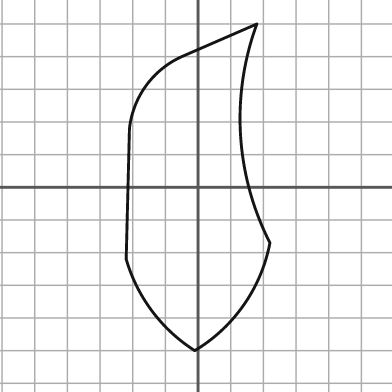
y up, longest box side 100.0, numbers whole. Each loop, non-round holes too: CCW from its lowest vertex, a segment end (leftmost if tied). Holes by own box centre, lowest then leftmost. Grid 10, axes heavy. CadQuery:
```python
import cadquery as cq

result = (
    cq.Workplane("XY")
    .moveTo(-1.0, -50.0)
    .threePointArc((14.0, -36.0), (22.0, -17.0))
    .threePointArc((13.0, 16.0), (18.0, 50.0))
    .lineTo(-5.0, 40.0)
    .threePointArc((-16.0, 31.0), (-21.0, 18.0))
    .lineTo(-22.0, -22.0)
    .threePointArc((-14.0, -38.0), (-1.0, -50.0))
    .close()
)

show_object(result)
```